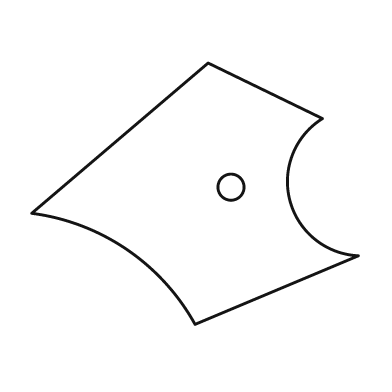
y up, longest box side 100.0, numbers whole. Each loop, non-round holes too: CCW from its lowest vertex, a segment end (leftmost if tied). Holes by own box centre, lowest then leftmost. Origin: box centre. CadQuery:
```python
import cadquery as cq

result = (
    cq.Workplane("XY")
    .moveTo(0.0, -40.0)
    .lineTo(50.0, -19.0)
    .threePointArc((29.0, -2.0), (39.0, 23.0))
    .lineTo(4.0, 40.0)
    .lineTo(-50.0, -6.0)
    .threePointArc((-21.0, -17.0), (0.0, -40.0))
    .close()
    .moveTo(11.0, 2.0)
    .circle(4.0)
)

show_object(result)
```